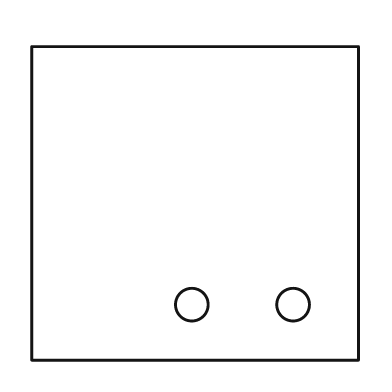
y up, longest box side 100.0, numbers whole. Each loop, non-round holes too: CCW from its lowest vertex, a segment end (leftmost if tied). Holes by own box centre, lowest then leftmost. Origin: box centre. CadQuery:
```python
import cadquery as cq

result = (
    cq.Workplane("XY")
    .moveTo(-50.0, -48.0)
    .lineTo(50.0, -48.0)
    .lineTo(50.0, 48.0)
    .lineTo(-50.0, 48.0)
    .close()
    .moveTo(-1.0, -31.0)
    .circle(5.0)
    .moveTo(30.0, -31.0)
    .circle(5.0)
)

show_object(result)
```